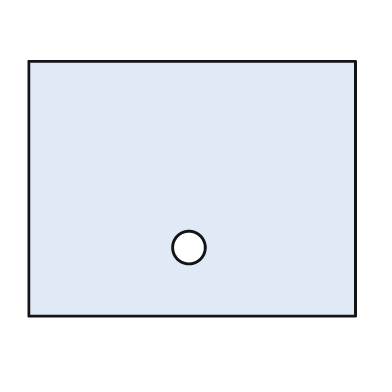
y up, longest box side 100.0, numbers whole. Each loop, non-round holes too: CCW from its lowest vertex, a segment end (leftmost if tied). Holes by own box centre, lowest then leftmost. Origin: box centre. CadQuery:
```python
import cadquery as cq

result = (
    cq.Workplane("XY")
    .moveTo(-50.0, -39.0)
    .lineTo(50.0, -39.0)
    .lineTo(50.0, 39.0)
    .lineTo(-50.0, 39.0)
    .close()
    .moveTo(-1.0, -18.0)
    .circle(5.0)
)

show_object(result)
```